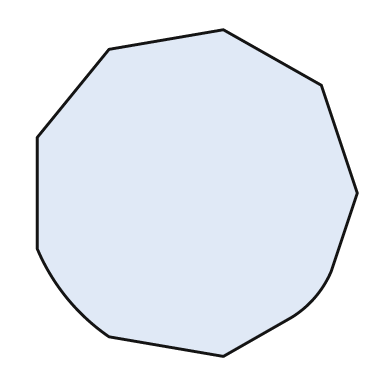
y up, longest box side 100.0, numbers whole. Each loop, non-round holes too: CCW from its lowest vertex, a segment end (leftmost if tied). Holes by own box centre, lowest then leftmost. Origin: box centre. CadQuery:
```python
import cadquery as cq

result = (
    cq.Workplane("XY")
    .moveTo(8.0, -50.0)
    .lineTo(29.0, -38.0)
    .threePointArc((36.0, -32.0), (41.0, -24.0))
    .lineTo(49.0, 0.0)
    .lineTo(38.0, 33.0)
    .lineTo(8.0, 50.0)
    .lineTo(-27.0, 44.0)
    .lineTo(-49.0, 17.0)
    .lineTo(-49.0, -17.0)
    .threePointArc((-40.0, -32.0), (-27.0, -44.0))
    .close()
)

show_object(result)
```